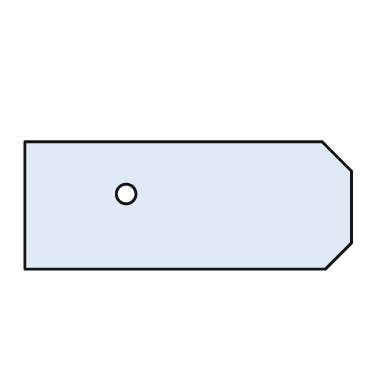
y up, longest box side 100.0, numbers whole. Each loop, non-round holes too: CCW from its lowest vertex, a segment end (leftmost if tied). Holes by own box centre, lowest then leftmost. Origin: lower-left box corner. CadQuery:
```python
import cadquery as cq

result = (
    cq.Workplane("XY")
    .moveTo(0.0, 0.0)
    .lineTo(92.0, 0.0)
    .lineTo(100.0, 8.0)
    .lineTo(100.0, 30.0)
    .lineTo(91.0, 39.0)
    .lineTo(0.0, 39.0)
    .close()
    .moveTo(31.0, 23.0)
    .circle(3.0)
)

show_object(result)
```